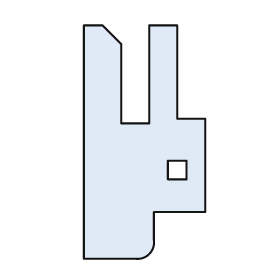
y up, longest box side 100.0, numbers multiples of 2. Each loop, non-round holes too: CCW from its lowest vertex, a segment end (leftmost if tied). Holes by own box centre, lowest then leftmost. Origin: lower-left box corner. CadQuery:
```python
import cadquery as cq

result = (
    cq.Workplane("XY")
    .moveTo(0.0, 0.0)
    .lineTo(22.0, 0.0)
    .threePointArc((28.0, 2.0), (30.0, 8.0))
    .lineTo(30.0, 20.0)
    .lineTo(52.0, 20.0)
    .lineTo(52.0, 60.0)
    .lineTo(40.0, 60.0)
    .lineTo(40.0, 100.0)
    .lineTo(28.0, 100.0)
    .lineTo(28.0, 58.0)
    .lineTo(16.0, 58.0)
    .lineTo(16.0, 92.0)
    .lineTo(8.0, 100.0)
    .lineTo(0.0, 100.0)
    .close()
    .moveTo(36.0, 34.0)
    .lineTo(44.0, 34.0)
    .lineTo(44.0, 42.0)
    .lineTo(36.0, 42.0)
    .close()
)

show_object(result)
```